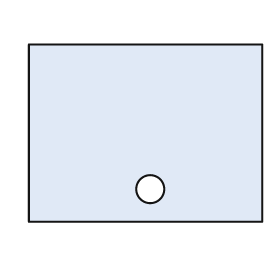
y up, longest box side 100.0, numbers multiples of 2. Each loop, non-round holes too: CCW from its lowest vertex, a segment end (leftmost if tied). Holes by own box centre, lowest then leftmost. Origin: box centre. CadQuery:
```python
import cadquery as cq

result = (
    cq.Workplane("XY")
    .moveTo(-50.0, -38.0)
    .lineTo(50.0, -38.0)
    .lineTo(50.0, 38.0)
    .lineTo(-50.0, 38.0)
    .close()
    .moveTo(2.0, -24.0)
    .circle(6.0)
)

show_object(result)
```